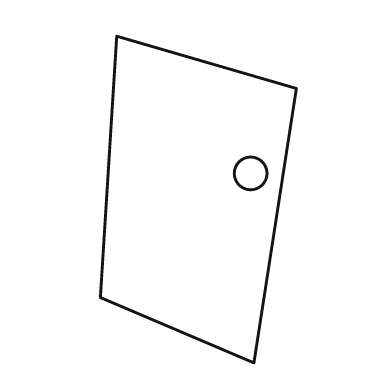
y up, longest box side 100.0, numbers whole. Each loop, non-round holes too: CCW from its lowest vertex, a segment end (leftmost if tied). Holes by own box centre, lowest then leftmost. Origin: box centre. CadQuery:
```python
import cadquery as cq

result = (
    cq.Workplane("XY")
    .moveTo(17.0, -50.0)
    .lineTo(30.0, 34.0)
    .lineTo(-25.0, 50.0)
    .lineTo(-30.0, -30.0)
    .close()
    .moveTo(16.0, 8.0)
    .circle(5.0)
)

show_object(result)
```